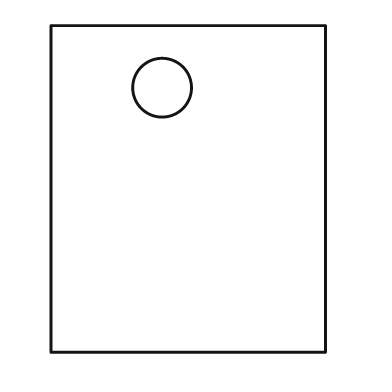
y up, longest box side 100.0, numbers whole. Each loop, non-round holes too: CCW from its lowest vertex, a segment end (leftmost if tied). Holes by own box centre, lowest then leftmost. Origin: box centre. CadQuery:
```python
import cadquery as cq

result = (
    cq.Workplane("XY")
    .moveTo(-42.0, -50.0)
    .lineTo(42.0, -50.0)
    .lineTo(42.0, 50.0)
    .lineTo(-42.0, 50.0)
    .close()
    .moveTo(-8.0, 31.0)
    .circle(9.0)
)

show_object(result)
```